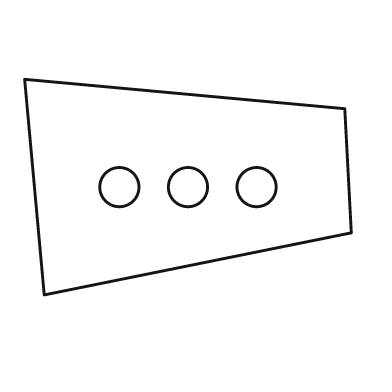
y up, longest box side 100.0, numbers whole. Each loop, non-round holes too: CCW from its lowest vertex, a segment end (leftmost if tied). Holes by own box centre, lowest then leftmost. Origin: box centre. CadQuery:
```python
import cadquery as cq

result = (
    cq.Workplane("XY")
    .moveTo(-44.0, -33.0)
    .lineTo(50.0, -14.0)
    .lineTo(48.0, 24.0)
    .lineTo(-50.0, 33.0)
    .close()
    .moveTo(-21.0, 0.0)
    .circle(6.0)
    .moveTo(0.0, 0.0)
    .circle(6.0)
    .moveTo(21.0, 0.0)
    .circle(6.0)
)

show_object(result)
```